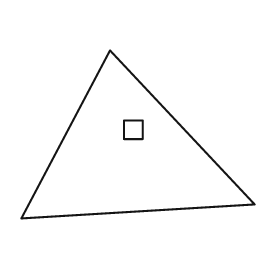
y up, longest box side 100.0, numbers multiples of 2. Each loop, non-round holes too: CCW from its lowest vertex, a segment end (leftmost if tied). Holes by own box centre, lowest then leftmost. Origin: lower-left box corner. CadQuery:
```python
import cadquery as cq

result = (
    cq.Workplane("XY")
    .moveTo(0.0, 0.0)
    .lineTo(100.0, 6.0)
    .lineTo(38.0, 72.0)
    .close()
    .moveTo(44.0, 34.0)
    .lineTo(52.0, 34.0)
    .lineTo(52.0, 42.0)
    .lineTo(44.0, 42.0)
    .close()
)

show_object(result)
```